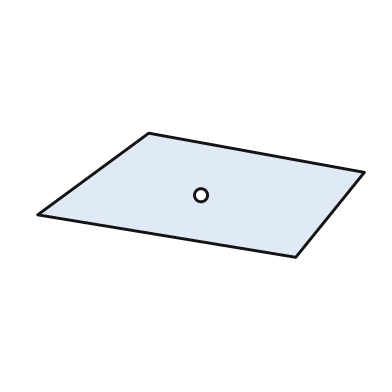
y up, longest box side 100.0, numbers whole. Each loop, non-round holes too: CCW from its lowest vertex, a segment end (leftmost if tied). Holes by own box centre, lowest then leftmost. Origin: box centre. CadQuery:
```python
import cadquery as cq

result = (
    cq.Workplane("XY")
    .moveTo(29.0, -19.0)
    .lineTo(50.0, 7.0)
    .lineTo(-16.0, 19.0)
    .lineTo(-50.0, -6.0)
    .close()
    .moveTo(0.0, 0.0)
    .circle(2.0)
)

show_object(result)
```